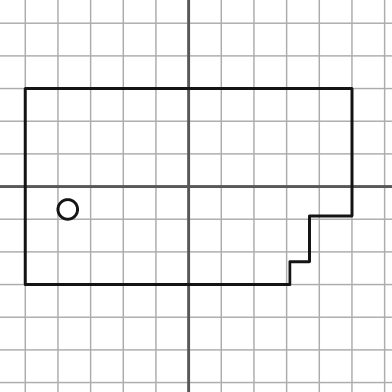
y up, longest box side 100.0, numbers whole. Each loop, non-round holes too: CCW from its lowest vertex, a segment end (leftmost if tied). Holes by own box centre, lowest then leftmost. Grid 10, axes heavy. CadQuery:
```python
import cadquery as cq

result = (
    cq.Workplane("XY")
    .moveTo(-50.0, -30.0)
    .lineTo(31.0, -30.0)
    .lineTo(31.0, -23.0)
    .lineTo(37.0, -23.0)
    .lineTo(37.0, -9.0)
    .lineTo(50.0, -9.0)
    .lineTo(50.0, 30.0)
    .lineTo(-50.0, 30.0)
    .close()
    .moveTo(-37.0, -7.0)
    .circle(3.0)
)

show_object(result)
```